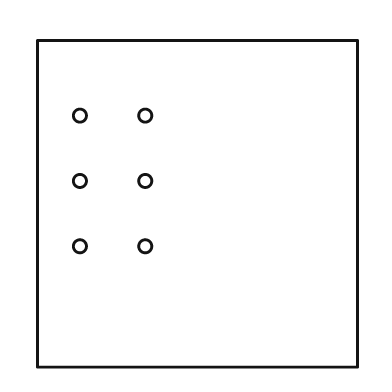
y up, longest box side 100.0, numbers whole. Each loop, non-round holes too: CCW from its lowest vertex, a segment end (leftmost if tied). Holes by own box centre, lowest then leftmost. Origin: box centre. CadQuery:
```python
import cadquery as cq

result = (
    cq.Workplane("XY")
    .moveTo(-49.0, -50.0)
    .lineTo(49.0, -50.0)
    .lineTo(49.0, 50.0)
    .lineTo(-49.0, 50.0)
    .close()
    .moveTo(-36.0, -13.0)
    .circle(2.0)
    .moveTo(-16.0, -13.0)
    .circle(2.0)
    .moveTo(-36.0, 7.0)
    .circle(2.0)
    .moveTo(-16.0, 7.0)
    .circle(2.0)
    .moveTo(-36.0, 27.0)
    .circle(2.0)
    .moveTo(-16.0, 27.0)
    .circle(2.0)
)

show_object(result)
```